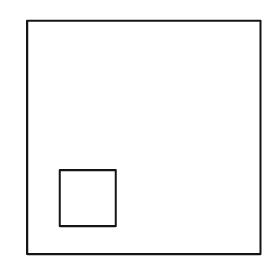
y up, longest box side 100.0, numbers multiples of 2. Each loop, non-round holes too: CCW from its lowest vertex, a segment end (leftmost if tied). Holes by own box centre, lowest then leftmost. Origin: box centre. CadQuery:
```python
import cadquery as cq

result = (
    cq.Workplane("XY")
    .moveTo(-50.0, -50.0)
    .lineTo(50.0, -50.0)
    .lineTo(50.0, 50.0)
    .lineTo(-50.0, 50.0)
    .close()
    .moveTo(-36.0, -38.0)
    .lineTo(-12.0, -38.0)
    .lineTo(-12.0, -14.0)
    .lineTo(-36.0, -14.0)
    .close()
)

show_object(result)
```